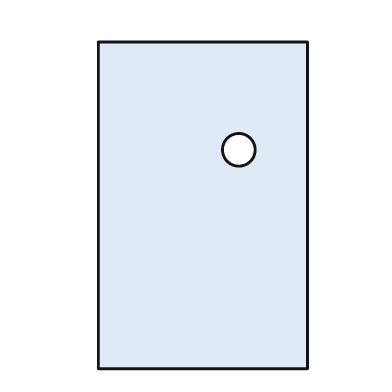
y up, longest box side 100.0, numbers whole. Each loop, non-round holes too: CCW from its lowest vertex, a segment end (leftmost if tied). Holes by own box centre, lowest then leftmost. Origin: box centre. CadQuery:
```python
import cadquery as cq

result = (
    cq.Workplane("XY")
    .moveTo(-32.0, -50.0)
    .lineTo(32.0, -50.0)
    .lineTo(32.0, 50.0)
    .lineTo(-32.0, 50.0)
    .close()
    .moveTo(11.0, 17.0)
    .circle(5.0)
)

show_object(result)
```